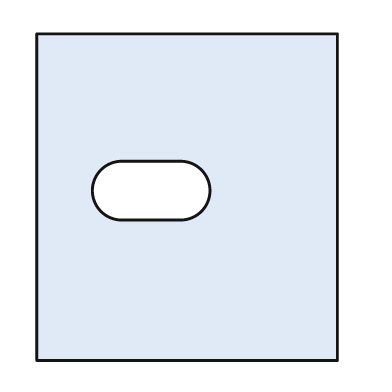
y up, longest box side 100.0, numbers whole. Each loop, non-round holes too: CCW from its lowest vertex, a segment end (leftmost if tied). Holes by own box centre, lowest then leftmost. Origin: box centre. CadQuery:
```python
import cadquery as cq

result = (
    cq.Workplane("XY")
    .moveTo(-46.0, -50.0)
    .lineTo(46.0, -50.0)
    .lineTo(46.0, 50.0)
    .lineTo(-46.0, 50.0)
    .close()
    .moveTo(-20.0, -7.0)
    .lineTo(-2.0, -7.0)
    .threePointArc((7.0, 2.0), (-2.0, 11.0))
    .lineTo(-20.0, 11.0)
    .threePointArc((-29.0, 2.0), (-20.0, -7.0))
    .close()
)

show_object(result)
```